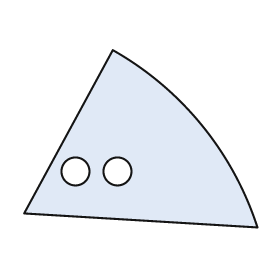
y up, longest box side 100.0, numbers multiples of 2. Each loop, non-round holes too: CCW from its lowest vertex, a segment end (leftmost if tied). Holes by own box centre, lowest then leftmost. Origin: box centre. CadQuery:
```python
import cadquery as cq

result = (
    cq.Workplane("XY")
    .moveTo(50.0, -38.0)
    .threePointArc((26.0, 6.0), (-12.0, 38.0))
    .lineTo(-50.0, -32.0)
    .close()
    .moveTo(-28.0, -14.0)
    .circle(6.0)
    .moveTo(-10.0, -14.0)
    .circle(6.0)
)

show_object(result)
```